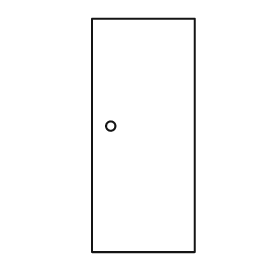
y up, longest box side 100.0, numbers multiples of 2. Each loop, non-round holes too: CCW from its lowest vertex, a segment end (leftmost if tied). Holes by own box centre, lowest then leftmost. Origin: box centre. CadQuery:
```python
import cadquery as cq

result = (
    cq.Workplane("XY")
    .moveTo(-22.0, -50.0)
    .lineTo(22.0, -50.0)
    .lineTo(22.0, 50.0)
    .lineTo(-22.0, 50.0)
    .close()
    .moveTo(-14.0, 4.0)
    .circle(2.0)
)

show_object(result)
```